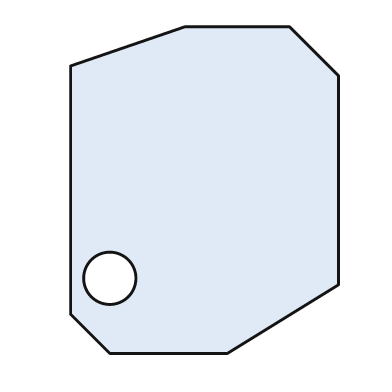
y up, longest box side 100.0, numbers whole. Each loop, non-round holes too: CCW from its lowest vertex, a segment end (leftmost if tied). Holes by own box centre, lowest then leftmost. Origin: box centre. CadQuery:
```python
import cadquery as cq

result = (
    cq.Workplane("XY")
    .moveTo(-29.0, -50.0)
    .lineTo(7.0, -50.0)
    .lineTo(41.0, -29.0)
    .lineTo(41.0, 35.0)
    .lineTo(26.0, 50.0)
    .lineTo(-6.0, 50.0)
    .lineTo(-41.0, 38.0)
    .lineTo(-41.0, -38.0)
    .close()
    .moveTo(-29.0, -27.0)
    .circle(8.0)
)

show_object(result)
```